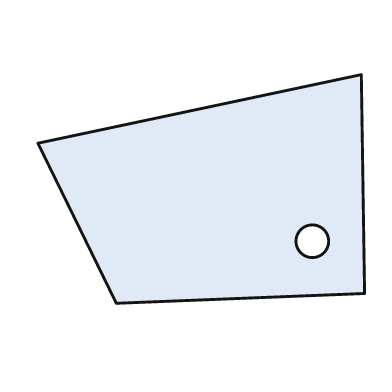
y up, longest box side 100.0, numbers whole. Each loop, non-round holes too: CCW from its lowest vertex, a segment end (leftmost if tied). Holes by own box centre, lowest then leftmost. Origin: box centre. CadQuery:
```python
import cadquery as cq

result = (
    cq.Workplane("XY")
    .moveTo(-26.0, -35.0)
    .lineTo(50.0, -32.0)
    .lineTo(49.0, 35.0)
    .lineTo(-50.0, 14.0)
    .close()
    .moveTo(34.0, -16.0)
    .circle(5.0)
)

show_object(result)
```